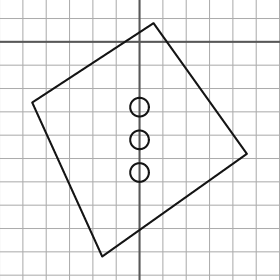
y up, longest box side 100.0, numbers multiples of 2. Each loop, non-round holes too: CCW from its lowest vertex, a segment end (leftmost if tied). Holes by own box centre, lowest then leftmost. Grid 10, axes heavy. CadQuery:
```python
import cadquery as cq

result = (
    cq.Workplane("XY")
    .moveTo(-16.0, -92.0)
    .lineTo(46.0, -48.0)
    .lineTo(6.0, 8.0)
    .lineTo(-46.0, -26.0)
    .close()
    .moveTo(0.0, -56.0)
    .circle(4.0)
    .moveTo(0.0, -42.0)
    .circle(4.0)
    .moveTo(0.0, -28.0)
    .circle(4.0)
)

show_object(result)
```